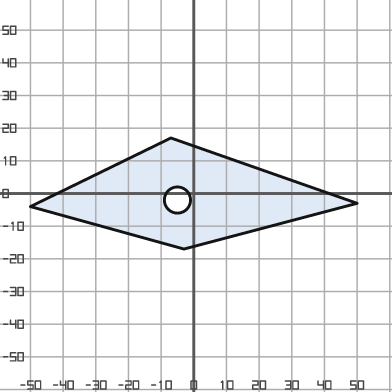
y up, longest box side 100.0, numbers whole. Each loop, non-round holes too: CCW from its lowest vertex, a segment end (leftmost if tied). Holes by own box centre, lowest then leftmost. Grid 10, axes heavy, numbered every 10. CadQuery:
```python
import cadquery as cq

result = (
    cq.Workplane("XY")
    .moveTo(-3.0, -17.0)
    .lineTo(50.0, -3.0)
    .lineTo(-7.0, 17.0)
    .lineTo(-50.0, -4.0)
    .close()
    .moveTo(-5.0, -2.0)
    .circle(4.0)
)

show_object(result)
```